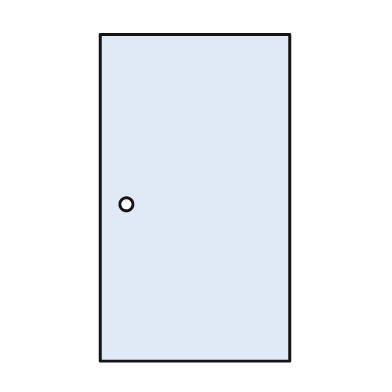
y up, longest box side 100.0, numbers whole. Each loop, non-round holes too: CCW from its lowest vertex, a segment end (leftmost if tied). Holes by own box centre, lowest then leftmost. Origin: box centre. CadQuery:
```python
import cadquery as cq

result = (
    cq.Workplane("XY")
    .moveTo(-29.0, -50.0)
    .lineTo(29.0, -50.0)
    .lineTo(29.0, 50.0)
    .lineTo(-29.0, 50.0)
    .close()
    .moveTo(-21.0, -2.0)
    .circle(2.0)
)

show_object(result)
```